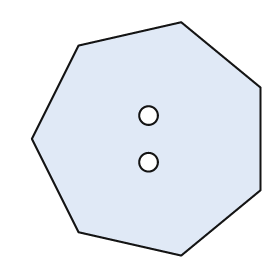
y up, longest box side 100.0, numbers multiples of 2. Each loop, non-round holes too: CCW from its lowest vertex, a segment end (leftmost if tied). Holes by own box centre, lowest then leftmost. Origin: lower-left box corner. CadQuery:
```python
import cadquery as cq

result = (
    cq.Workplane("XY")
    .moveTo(64.0, 0.0)
    .lineTo(98.0, 28.0)
    .lineTo(98.0, 72.0)
    .lineTo(64.0, 100.0)
    .lineTo(20.0, 90.0)
    .lineTo(0.0, 50.0)
    .lineTo(20.0, 10.0)
    .close()
    .moveTo(50.0, 40.0)
    .circle(4.0)
    .moveTo(50.0, 60.0)
    .circle(4.0)
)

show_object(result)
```